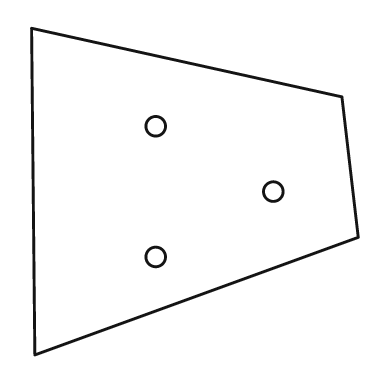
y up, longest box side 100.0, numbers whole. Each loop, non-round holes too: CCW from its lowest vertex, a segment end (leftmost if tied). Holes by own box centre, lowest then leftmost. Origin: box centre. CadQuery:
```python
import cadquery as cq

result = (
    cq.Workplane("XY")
    .moveTo(-49.0, -50.0)
    .lineTo(50.0, -14.0)
    .lineTo(45.0, 29.0)
    .lineTo(-50.0, 50.0)
    .close()
    .moveTo(-12.0, -20.0)
    .circle(3.0)
    .moveTo(24.0, 0.0)
    .circle(3.0)
    .moveTo(-12.0, 20.0)
    .circle(3.0)
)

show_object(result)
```